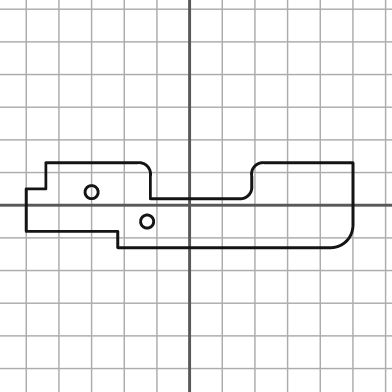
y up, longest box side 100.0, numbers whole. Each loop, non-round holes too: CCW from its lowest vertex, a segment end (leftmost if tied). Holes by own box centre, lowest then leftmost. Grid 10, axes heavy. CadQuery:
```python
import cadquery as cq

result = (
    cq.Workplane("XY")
    .moveTo(-22.0, -13.0)
    .lineTo(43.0, -13.0)
    .threePointArc((48.0, -11.0), (50.0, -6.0))
    .lineTo(50.0, 13.0)
    .lineTo(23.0, 13.0)
    .threePointArc((20.0, 12.0), (19.0, 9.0))
    .lineTo(19.0, 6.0)
    .threePointArc((18.0, 3.0), (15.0, 2.0))
    .lineTo(-12.0, 2.0)
    .lineTo(-12.0, 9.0)
    .threePointArc((-13.0, 12.0), (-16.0, 13.0))
    .lineTo(-44.0, 13.0)
    .lineTo(-44.0, 5.0)
    .lineTo(-50.0, 5.0)
    .lineTo(-50.0, -8.0)
    .lineTo(-22.0, -8.0)
    .close()
    .moveTo(-13.0, -5.0)
    .circle(2.0)
    .moveTo(-30.0, 4.0)
    .circle(2.0)
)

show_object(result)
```